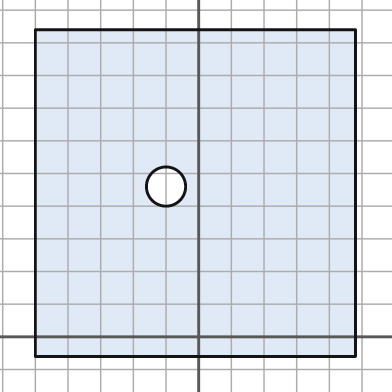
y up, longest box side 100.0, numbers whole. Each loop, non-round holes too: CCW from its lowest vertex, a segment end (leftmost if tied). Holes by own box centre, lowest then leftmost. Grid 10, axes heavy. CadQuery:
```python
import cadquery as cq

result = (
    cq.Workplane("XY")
    .moveTo(-50.0, -6.0)
    .lineTo(48.0, -6.0)
    .lineTo(48.0, 94.0)
    .lineTo(-50.0, 94.0)
    .close()
    .moveTo(-10.0, 46.0)
    .circle(6.0)
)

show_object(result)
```